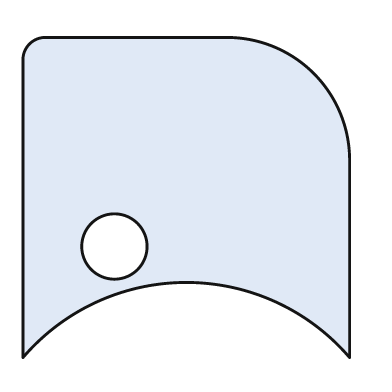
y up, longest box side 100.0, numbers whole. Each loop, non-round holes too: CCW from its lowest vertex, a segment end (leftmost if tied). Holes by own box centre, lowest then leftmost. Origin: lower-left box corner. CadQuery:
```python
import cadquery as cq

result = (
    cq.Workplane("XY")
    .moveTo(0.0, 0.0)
    .threePointArc((50.0, 23.0), (100.0, 0.0))
    .lineTo(100.0, 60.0)
    .threePointArc((89.0, 87.0), (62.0, 98.0))
    .lineTo(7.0, 98.0)
    .threePointArc((2.0, 96.0), (0.0, 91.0))
    .close()
    .moveTo(28.0, 34.0)
    .circle(10.0)
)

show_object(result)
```